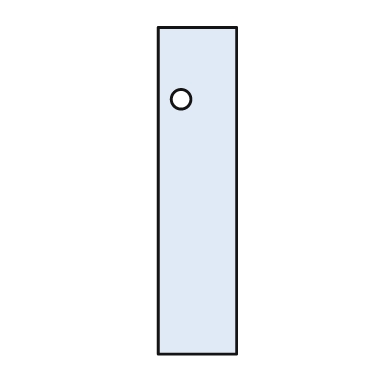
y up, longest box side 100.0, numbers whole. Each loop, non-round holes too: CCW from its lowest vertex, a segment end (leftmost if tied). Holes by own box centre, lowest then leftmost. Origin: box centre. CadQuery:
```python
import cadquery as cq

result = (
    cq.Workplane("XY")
    .moveTo(-12.0, -50.0)
    .lineTo(12.0, -50.0)
    .lineTo(12.0, 50.0)
    .lineTo(-12.0, 50.0)
    .close()
    .moveTo(-5.0, 28.0)
    .circle(3.0)
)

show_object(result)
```